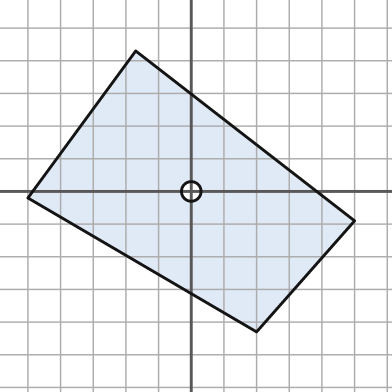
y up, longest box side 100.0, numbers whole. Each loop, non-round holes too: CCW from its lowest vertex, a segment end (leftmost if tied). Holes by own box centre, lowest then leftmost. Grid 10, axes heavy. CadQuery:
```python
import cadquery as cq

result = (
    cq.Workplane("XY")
    .moveTo(20.0, -43.0)
    .lineTo(50.0, -9.0)
    .lineTo(-17.0, 43.0)
    .lineTo(-50.0, -2.0)
    .close()
    .moveTo(0.0, 0.0)
    .circle(3.0)
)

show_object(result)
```